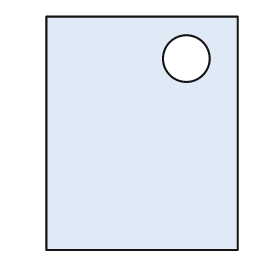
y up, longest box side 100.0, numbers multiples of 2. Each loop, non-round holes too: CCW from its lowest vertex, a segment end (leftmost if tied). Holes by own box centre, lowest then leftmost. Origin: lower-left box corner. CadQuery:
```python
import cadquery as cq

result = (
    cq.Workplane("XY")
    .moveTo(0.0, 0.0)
    .lineTo(82.0, 0.0)
    .lineTo(82.0, 100.0)
    .lineTo(0.0, 100.0)
    .close()
    .moveTo(60.0, 82.0)
    .circle(10.0)
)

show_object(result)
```